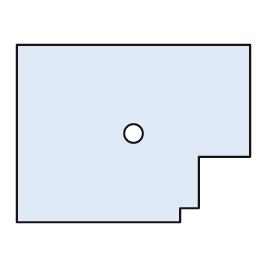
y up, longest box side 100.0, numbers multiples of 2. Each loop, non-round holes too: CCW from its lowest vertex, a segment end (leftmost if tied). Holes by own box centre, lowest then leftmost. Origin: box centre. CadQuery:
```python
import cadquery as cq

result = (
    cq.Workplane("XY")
    .moveTo(-50.0, -38.0)
    .lineTo(20.0, -38.0)
    .lineTo(20.0, -32.0)
    .lineTo(28.0, -32.0)
    .lineTo(28.0, -10.0)
    .lineTo(50.0, -10.0)
    .lineTo(50.0, 38.0)
    .lineTo(-50.0, 38.0)
    .close()
    .moveTo(0.0, 0.0)
    .circle(4.0)
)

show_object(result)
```